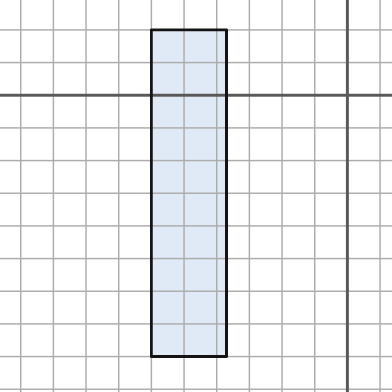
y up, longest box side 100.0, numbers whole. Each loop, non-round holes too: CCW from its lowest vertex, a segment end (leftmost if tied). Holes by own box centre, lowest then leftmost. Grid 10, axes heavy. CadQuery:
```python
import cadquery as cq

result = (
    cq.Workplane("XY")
    .moveTo(-60.0, -80.0)
    .lineTo(-37.0, -80.0)
    .lineTo(-37.0, 20.0)
    .lineTo(-60.0, 20.0)
    .close()
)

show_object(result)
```